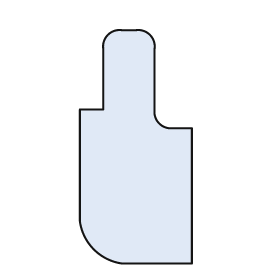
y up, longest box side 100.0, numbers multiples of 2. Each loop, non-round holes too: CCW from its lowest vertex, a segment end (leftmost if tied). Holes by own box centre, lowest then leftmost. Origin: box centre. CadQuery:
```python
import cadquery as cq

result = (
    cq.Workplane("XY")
    .moveTo(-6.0, -50.0)
    .lineTo(24.0, -50.0)
    .lineTo(24.0, 8.0)
    .lineTo(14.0, 8.0)
    .threePointArc((10.0, 10.0), (8.0, 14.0))
    .lineTo(8.0, 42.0)
    .threePointArc((6.0, 48.0), (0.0, 50.0))
    .lineTo(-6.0, 50.0)
    .threePointArc((-12.0, 48.0), (-14.0, 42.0))
    .lineTo(-14.0, 16.0)
    .lineTo(-24.0, 16.0)
    .lineTo(-24.0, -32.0)
    .threePointArc((-18.0, -44.0), (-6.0, -50.0))
    .close()
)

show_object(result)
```